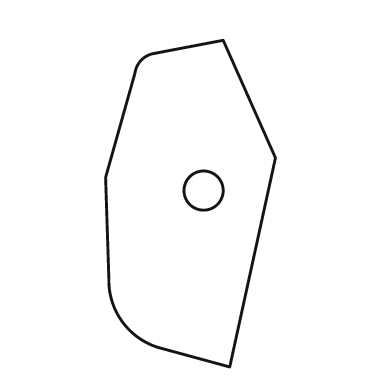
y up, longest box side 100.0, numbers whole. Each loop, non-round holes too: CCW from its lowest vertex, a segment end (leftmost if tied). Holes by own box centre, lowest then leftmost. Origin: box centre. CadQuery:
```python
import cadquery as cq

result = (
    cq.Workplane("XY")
    .moveTo(12.0, -50.0)
    .lineTo(26.0, 14.0)
    .lineTo(10.0, 50.0)
    .lineTo(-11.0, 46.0)
    .threePointArc((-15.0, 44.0), (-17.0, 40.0))
    .lineTo(-26.0, 8.0)
    .lineTo(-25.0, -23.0)
    .threePointArc((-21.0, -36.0), (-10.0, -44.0))
    .close()
    .moveTo(4.0, 4.0)
    .circle(6.0)
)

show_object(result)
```